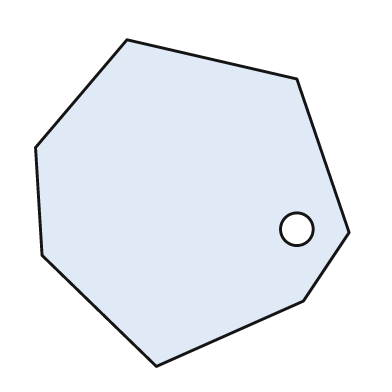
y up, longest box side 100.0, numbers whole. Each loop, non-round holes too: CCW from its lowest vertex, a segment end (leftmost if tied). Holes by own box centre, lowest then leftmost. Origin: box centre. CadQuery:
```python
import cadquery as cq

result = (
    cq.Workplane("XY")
    .moveTo(-11.0, -50.0)
    .lineTo(34.0, -30.0)
    .lineTo(48.0, -9.0)
    .lineTo(32.0, 38.0)
    .lineTo(-20.0, 50.0)
    .lineTo(-48.0, 17.0)
    .lineTo(-46.0, -16.0)
    .close()
    .moveTo(32.0, -8.0)
    .circle(5.0)
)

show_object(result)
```